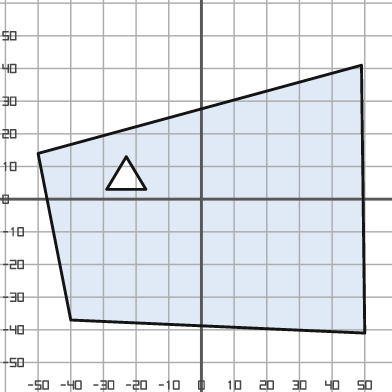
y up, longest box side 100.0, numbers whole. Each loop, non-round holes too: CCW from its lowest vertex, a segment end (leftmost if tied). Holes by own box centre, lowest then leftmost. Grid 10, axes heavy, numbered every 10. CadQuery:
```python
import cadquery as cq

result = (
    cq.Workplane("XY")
    .moveTo(50.0, -41.0)
    .lineTo(49.0, 41.0)
    .lineTo(-50.0, 14.0)
    .lineTo(-40.0, -37.0)
    .close()
    .moveTo(-29.0, 3.0)
    .lineTo(-17.0, 3.0)
    .lineTo(-23.0, 13.0)
    .close()
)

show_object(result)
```